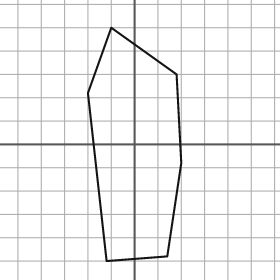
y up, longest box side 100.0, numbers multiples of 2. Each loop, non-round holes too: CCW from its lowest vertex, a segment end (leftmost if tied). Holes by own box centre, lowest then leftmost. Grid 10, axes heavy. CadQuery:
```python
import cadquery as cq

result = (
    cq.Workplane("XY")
    .moveTo(-12.0, -50.0)
    .lineTo(14.0, -48.0)
    .lineTo(20.0, -8.0)
    .lineTo(18.0, 30.0)
    .lineTo(-10.0, 50.0)
    .lineTo(-20.0, 22.0)
    .close()
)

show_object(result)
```